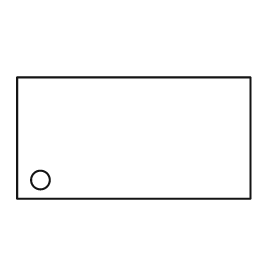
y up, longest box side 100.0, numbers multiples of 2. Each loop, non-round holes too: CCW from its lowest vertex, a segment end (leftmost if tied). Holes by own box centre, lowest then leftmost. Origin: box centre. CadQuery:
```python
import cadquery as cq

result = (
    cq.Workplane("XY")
    .moveTo(-50.0, -26.0)
    .lineTo(50.0, -26.0)
    .lineTo(50.0, 26.0)
    .lineTo(-50.0, 26.0)
    .close()
    .moveTo(-40.0, -18.0)
    .circle(4.0)
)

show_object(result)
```